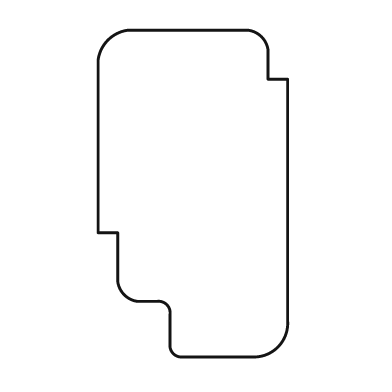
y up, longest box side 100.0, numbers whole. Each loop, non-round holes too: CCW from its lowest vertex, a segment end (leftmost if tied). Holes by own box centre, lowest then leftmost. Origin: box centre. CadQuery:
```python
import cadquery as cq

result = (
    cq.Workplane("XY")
    .moveTo(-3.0, -50.0)
    .lineTo(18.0, -50.0)
    .threePointArc((26.0, -47.0), (29.0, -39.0))
    .lineTo(29.0, 35.0)
    .lineTo(23.0, 35.0)
    .lineTo(23.0, 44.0)
    .threePointArc((21.0, 48.0), (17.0, 50.0))
    .lineTo(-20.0, 50.0)
    .threePointArc((-26.0, 47.0), (-29.0, 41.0))
    .lineTo(-29.0, -12.0)
    .lineTo(-23.0, -12.0)
    .lineTo(-23.0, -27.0)
    .threePointArc((-21.0, -31.0), (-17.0, -33.0))
    .lineTo(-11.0, -33.0)
    .threePointArc((-8.0, -34.0), (-7.0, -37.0))
    .lineTo(-7.0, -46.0)
    .threePointArc((-6.0, -49.0), (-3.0, -50.0))
    .close()
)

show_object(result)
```